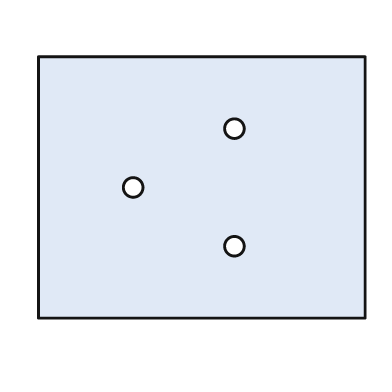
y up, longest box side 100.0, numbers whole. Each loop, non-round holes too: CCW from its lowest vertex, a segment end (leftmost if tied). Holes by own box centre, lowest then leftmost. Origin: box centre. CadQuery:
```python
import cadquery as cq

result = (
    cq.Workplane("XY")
    .moveTo(-50.0, -40.0)
    .lineTo(50.0, -40.0)
    .lineTo(50.0, 40.0)
    .lineTo(-50.0, 40.0)
    .close()
    .moveTo(10.0, -18.0)
    .circle(3.0)
    .moveTo(-21.0, 0.0)
    .circle(3.0)
    .moveTo(10.0, 18.0)
    .circle(3.0)
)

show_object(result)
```